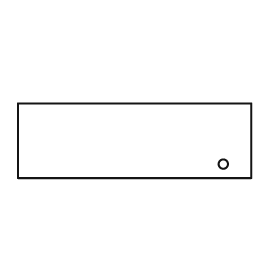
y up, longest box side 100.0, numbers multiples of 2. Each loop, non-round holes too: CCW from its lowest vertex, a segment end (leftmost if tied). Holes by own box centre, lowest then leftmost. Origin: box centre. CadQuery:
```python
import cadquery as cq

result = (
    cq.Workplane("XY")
    .moveTo(-50.0, -16.0)
    .lineTo(50.0, -16.0)
    .lineTo(50.0, 16.0)
    .lineTo(-50.0, 16.0)
    .close()
    .moveTo(38.0, -10.0)
    .circle(2.0)
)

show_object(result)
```